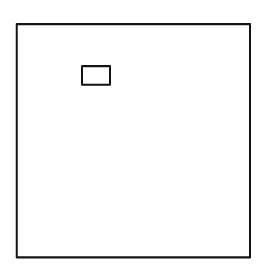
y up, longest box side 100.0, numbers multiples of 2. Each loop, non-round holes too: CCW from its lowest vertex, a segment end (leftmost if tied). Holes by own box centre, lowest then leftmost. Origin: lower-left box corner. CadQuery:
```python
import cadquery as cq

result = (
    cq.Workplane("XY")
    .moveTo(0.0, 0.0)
    .lineTo(100.0, 0.0)
    .lineTo(100.0, 100.0)
    .lineTo(0.0, 100.0)
    .close()
    .moveTo(28.0, 74.0)
    .lineTo(40.0, 74.0)
    .lineTo(40.0, 82.0)
    .lineTo(28.0, 82.0)
    .close()
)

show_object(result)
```